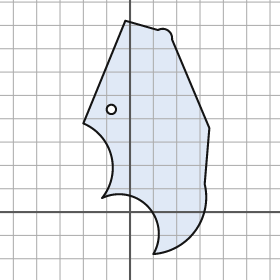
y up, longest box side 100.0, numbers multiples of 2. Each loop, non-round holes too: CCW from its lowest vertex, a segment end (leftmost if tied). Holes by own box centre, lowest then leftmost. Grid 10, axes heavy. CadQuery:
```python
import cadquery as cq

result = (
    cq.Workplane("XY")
    .moveTo(10.0, -18.0)
    .threePointArc((28.0, -8.0), (32.0, 12.0))
    .lineTo(34.0, 36.0)
    .lineTo(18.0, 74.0)
    .threePointArc((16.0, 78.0), (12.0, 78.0))
    .lineTo(-2.0, 82.0)
    .lineTo(-20.0, 38.0)
    .threePointArc((-8.0, 24.0), (-12.0, 6.0))
    .threePointArc((8.0, 2.0), (10.0, -18.0))
    .close()
    .moveTo(-8.0, 44.0)
    .circle(2.0)
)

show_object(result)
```